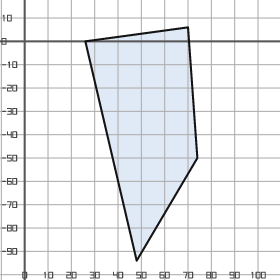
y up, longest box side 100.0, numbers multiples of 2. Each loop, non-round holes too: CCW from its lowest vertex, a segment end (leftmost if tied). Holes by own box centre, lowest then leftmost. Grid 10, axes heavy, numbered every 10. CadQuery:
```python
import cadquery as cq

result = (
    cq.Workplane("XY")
    .moveTo(48.0, -94.0)
    .lineTo(74.0, -50.0)
    .lineTo(70.0, 6.0)
    .lineTo(26.0, 0.0)
    .close()
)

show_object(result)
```